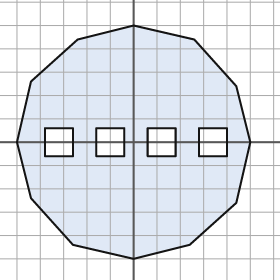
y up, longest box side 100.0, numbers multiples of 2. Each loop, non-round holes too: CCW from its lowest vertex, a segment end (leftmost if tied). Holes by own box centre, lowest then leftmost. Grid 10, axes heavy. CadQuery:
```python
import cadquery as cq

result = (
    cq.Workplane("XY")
    .moveTo(0.0, -50.0)
    .lineTo(24.0, -44.0)
    .lineTo(44.0, -26.0)
    .lineTo(50.0, 0.0)
    .lineTo(44.0, 24.0)
    .lineTo(26.0, 44.0)
    .lineTo(0.0, 50.0)
    .lineTo(-24.0, 44.0)
    .lineTo(-44.0, 26.0)
    .lineTo(-50.0, 0.0)
    .lineTo(-44.0, -24.0)
    .lineTo(-26.0, -44.0)
    .close()
    .moveTo(-38.0, -6.0)
    .lineTo(-26.0, -6.0)
    .lineTo(-26.0, 6.0)
    .lineTo(-38.0, 6.0)
    .close()
    .moveTo(-16.0, -6.0)
    .lineTo(-4.0, -6.0)
    .lineTo(-4.0, 6.0)
    .lineTo(-16.0, 6.0)
    .close()
    .moveTo(6.0, -6.0)
    .lineTo(18.0, -6.0)
    .lineTo(18.0, 6.0)
    .lineTo(6.0, 6.0)
    .close()
    .moveTo(28.0, -6.0)
    .lineTo(40.0, -6.0)
    .lineTo(40.0, 6.0)
    .lineTo(28.0, 6.0)
    .close()
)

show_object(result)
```